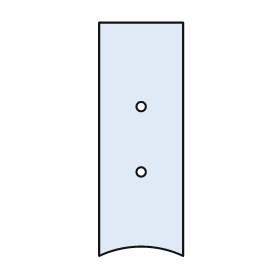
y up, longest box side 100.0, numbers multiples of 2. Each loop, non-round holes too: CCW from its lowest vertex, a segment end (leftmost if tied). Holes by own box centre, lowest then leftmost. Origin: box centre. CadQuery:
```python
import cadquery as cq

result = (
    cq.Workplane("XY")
    .moveTo(-18.0, -50.0)
    .threePointArc((0.0, -46.0), (18.0, -50.0))
    .lineTo(18.0, 50.0)
    .lineTo(-18.0, 50.0)
    .close()
    .moveTo(0.0, -14.0)
    .circle(2.0)
    .moveTo(0.0, 14.0)
    .circle(2.0)
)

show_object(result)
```